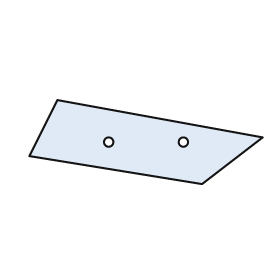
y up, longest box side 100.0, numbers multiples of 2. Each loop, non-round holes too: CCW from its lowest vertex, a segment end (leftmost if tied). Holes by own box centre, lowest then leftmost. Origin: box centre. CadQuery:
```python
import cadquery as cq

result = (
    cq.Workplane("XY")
    .moveTo(24.0, -18.0)
    .lineTo(50.0, 2.0)
    .lineTo(-38.0, 18.0)
    .lineTo(-50.0, -6.0)
    .close()
    .moveTo(-16.0, 0.0)
    .circle(2.0)
    .moveTo(16.0, 0.0)
    .circle(2.0)
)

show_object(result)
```